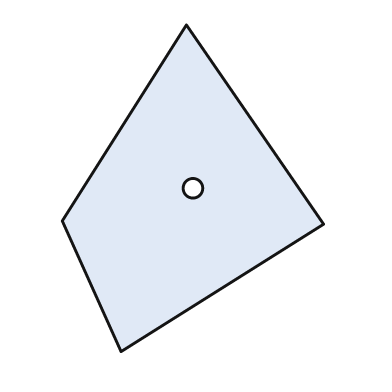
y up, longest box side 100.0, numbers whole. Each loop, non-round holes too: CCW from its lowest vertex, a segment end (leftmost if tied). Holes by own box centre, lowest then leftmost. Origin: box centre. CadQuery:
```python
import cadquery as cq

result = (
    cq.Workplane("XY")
    .moveTo(-22.0, -50.0)
    .lineTo(40.0, -11.0)
    .lineTo(-2.0, 50.0)
    .lineTo(-40.0, -10.0)
    .close()
    .moveTo(0.0, 0.0)
    .circle(3.0)
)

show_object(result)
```